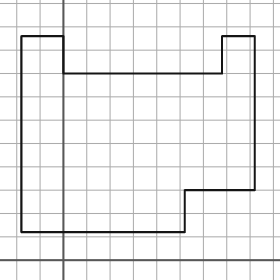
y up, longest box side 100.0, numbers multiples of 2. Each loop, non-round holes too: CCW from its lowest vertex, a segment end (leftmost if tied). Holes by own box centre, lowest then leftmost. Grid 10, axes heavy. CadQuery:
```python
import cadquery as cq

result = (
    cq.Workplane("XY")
    .moveTo(-18.0, 12.0)
    .lineTo(52.0, 12.0)
    .lineTo(52.0, 30.0)
    .lineTo(82.0, 30.0)
    .lineTo(82.0, 96.0)
    .lineTo(68.0, 96.0)
    .lineTo(68.0, 80.0)
    .lineTo(0.0, 80.0)
    .lineTo(0.0, 96.0)
    .lineTo(-18.0, 96.0)
    .close()
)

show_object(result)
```